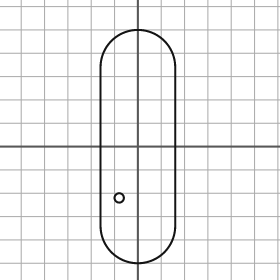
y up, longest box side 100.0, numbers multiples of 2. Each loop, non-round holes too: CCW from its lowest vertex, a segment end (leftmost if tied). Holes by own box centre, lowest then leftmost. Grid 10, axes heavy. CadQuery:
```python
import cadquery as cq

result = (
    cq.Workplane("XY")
    .moveTo(-16.0, -34.0)
    .threePointArc((0.0, -50.0), (16.0, -34.0))
    .lineTo(16.0, 34.0)
    .threePointArc((0.0, 50.0), (-16.0, 34.0))
    .close()
    .moveTo(-8.0, -22.0)
    .circle(2.0)
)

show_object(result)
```